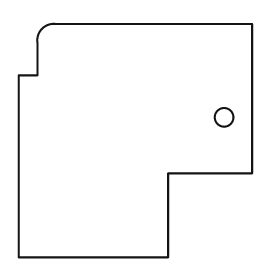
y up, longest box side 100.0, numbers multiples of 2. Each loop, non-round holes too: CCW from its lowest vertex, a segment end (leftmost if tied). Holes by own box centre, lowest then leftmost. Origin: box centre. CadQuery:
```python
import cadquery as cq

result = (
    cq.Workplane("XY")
    .moveTo(-50.0, -50.0)
    .lineTo(14.0, -50.0)
    .lineTo(14.0, -14.0)
    .lineTo(50.0, -14.0)
    .lineTo(50.0, 50.0)
    .lineTo(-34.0, 50.0)
    .threePointArc((-40.0, 48.0), (-42.0, 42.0))
    .lineTo(-42.0, 28.0)
    .lineTo(-50.0, 28.0)
    .close()
    .moveTo(38.0, 10.0)
    .circle(4.0)
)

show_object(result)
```